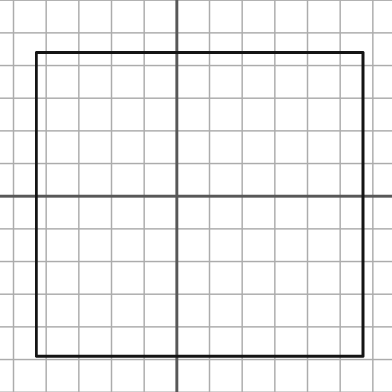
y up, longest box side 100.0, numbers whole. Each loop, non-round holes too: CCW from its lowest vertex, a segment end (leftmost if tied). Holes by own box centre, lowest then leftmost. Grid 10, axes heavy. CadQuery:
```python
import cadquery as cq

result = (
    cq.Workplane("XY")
    .moveTo(-43.0, -49.0)
    .lineTo(57.0, -49.0)
    .lineTo(57.0, 44.0)
    .lineTo(-43.0, 44.0)
    .close()
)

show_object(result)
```